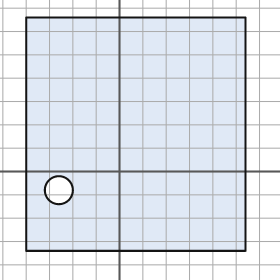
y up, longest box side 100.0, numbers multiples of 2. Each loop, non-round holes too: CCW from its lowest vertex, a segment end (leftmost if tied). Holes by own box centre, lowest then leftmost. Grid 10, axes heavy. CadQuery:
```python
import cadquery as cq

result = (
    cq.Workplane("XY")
    .moveTo(-40.0, -34.0)
    .lineTo(54.0, -34.0)
    .lineTo(54.0, 66.0)
    .lineTo(-40.0, 66.0)
    .close()
    .moveTo(-26.0, -8.0)
    .circle(6.0)
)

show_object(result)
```